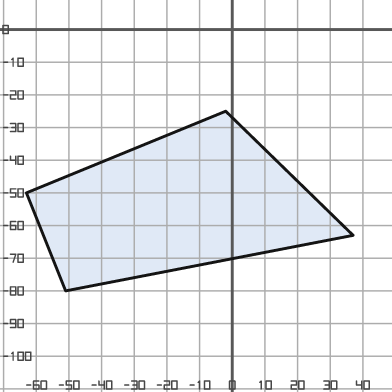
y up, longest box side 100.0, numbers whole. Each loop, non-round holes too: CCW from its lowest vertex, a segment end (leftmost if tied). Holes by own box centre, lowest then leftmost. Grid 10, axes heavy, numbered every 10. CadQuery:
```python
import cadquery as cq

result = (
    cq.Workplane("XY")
    .moveTo(-51.0, -80.0)
    .lineTo(37.0, -63.0)
    .lineTo(-2.0, -25.0)
    .lineTo(-63.0, -50.0)
    .close()
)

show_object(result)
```